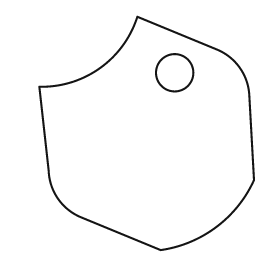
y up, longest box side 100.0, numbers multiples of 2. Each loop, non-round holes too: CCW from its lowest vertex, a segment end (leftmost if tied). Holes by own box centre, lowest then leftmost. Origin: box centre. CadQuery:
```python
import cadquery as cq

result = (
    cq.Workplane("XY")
    .moveTo(6.0, -50.0)
    .threePointArc((30.0, -40.0), (46.0, -20.0))
    .lineTo(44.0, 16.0)
    .threePointArc((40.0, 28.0), (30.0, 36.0))
    .lineTo(-4.0, 50.0)
    .threePointArc((-20.0, 28.0), (-46.0, 20.0))
    .lineTo(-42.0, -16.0)
    .threePointArc((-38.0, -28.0), (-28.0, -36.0))
    .close()
    .moveTo(12.0, 26.0)
    .circle(8.0)
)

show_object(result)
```